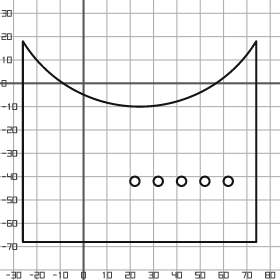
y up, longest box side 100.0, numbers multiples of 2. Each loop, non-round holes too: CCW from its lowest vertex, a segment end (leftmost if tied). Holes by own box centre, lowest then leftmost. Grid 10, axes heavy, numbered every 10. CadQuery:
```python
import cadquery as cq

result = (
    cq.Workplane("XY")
    .moveTo(-26.0, -68.0)
    .lineTo(74.0, -68.0)
    .lineTo(74.0, 18.0)
    .threePointArc((24.0, -10.0), (-26.0, 18.0))
    .close()
    .moveTo(22.0, -42.0)
    .circle(2.0)
    .moveTo(32.0, -42.0)
    .circle(2.0)
    .moveTo(42.0, -42.0)
    .circle(2.0)
    .moveTo(52.0, -42.0)
    .circle(2.0)
    .moveTo(62.0, -42.0)
    .circle(2.0)
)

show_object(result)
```